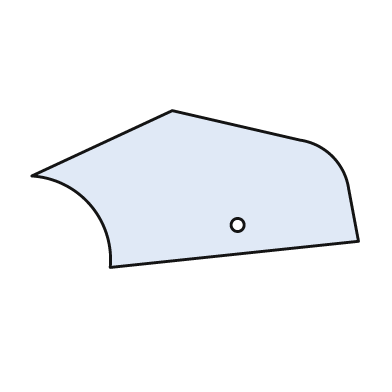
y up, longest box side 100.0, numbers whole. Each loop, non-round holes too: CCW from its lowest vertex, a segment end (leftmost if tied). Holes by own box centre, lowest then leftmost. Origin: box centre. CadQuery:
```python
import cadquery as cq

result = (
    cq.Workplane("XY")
    .moveTo(-26.0, -24.0)
    .lineTo(50.0, -16.0)
    .lineTo(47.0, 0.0)
    .threePointArc((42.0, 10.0), (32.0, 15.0))
    .lineTo(-7.0, 24.0)
    .lineTo(-50.0, 4.0)
    .threePointArc((-32.0, -5.0), (-26.0, -24.0))
    .close()
    .moveTo(13.0, -11.0)
    .circle(2.0)
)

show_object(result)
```